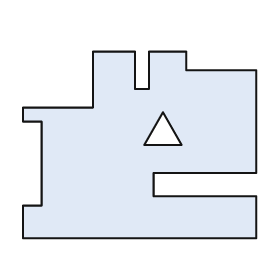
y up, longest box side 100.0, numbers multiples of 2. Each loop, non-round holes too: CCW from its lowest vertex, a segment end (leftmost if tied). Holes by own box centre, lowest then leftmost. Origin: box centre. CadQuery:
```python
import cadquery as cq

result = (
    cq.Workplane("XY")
    .moveTo(-50.0, -40.0)
    .lineTo(50.0, -40.0)
    .lineTo(50.0, -22.0)
    .lineTo(6.0, -22.0)
    .lineTo(6.0, -12.0)
    .lineTo(50.0, -12.0)
    .lineTo(50.0, 32.0)
    .lineTo(20.0, 32.0)
    .lineTo(20.0, 40.0)
    .lineTo(4.0, 40.0)
    .lineTo(4.0, 24.0)
    .lineTo(-2.0, 24.0)
    .lineTo(-2.0, 40.0)
    .lineTo(-20.0, 40.0)
    .lineTo(-20.0, 16.0)
    .lineTo(-50.0, 16.0)
    .lineTo(-50.0, 10.0)
    .lineTo(-42.0, 10.0)
    .lineTo(-42.0, -26.0)
    .lineTo(-50.0, -26.0)
    .close()
    .moveTo(2.0, 0.0)
    .lineTo(18.0, 0.0)
    .lineTo(10.0, 14.0)
    .close()
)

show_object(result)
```